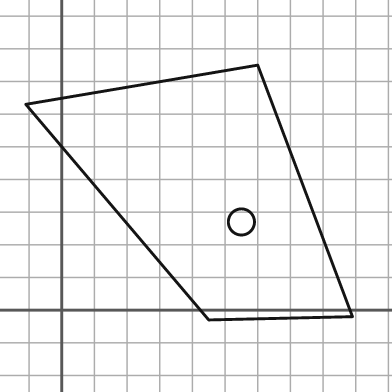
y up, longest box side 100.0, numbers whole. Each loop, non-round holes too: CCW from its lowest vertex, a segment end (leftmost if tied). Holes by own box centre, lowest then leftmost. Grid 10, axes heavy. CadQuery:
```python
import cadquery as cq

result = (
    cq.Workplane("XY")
    .moveTo(45.0, -3.0)
    .lineTo(89.0, -2.0)
    .lineTo(60.0, 75.0)
    .lineTo(-11.0, 63.0)
    .close()
    .moveTo(55.0, 27.0)
    .circle(4.0)
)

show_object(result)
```